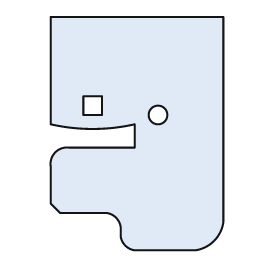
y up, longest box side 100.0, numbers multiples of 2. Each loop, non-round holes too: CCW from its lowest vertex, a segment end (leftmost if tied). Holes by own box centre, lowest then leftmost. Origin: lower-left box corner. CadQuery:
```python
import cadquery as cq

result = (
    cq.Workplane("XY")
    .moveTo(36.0, 0.0)
    .lineTo(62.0, 0.0)
    .threePointArc((70.0, 4.0), (74.0, 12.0))
    .lineTo(74.0, 100.0)
    .lineTo(0.0, 100.0)
    .lineTo(0.0, 54.0)
    .threePointArc((18.0, 52.0), (36.0, 54.0))
    .lineTo(36.0, 44.0)
    .lineTo(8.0, 44.0)
    .threePointArc((2.0, 42.0), (0.0, 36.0))
    .lineTo(0.0, 20.0)
    .lineTo(4.0, 16.0)
    .lineTo(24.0, 16.0)
    .threePointArc((28.0, 14.0), (30.0, 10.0))
    .lineTo(30.0, 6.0)
    .threePointArc((32.0, 2.0), (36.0, 0.0))
    .close()
    .moveTo(46.0, 58.0)
    .circle(4.0)
    .moveTo(14.0, 58.0)
    .lineTo(22.0, 58.0)
    .lineTo(22.0, 66.0)
    .lineTo(14.0, 66.0)
    .close()
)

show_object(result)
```